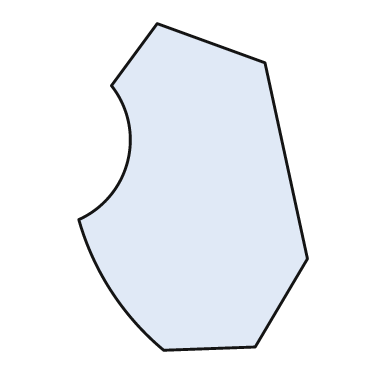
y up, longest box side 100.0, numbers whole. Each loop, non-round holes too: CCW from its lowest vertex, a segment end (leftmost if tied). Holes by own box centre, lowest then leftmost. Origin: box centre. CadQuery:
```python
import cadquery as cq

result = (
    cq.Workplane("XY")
    .moveTo(-9.0, -50.0)
    .lineTo(19.0, -49.0)
    .lineTo(35.0, -22.0)
    .lineTo(22.0, 38.0)
    .lineTo(-11.0, 50.0)
    .lineTo(-25.0, 31.0)
    .threePointArc((-20.0, 8.0), (-35.0, -10.0))
    .threePointArc((-25.0, -32.0), (-9.0, -50.0))
    .close()
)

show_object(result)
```